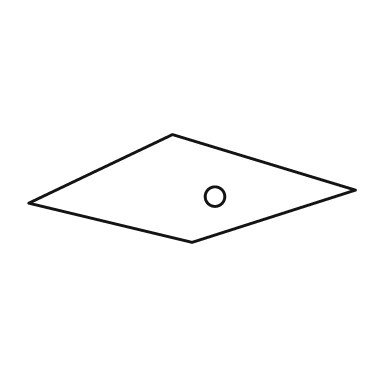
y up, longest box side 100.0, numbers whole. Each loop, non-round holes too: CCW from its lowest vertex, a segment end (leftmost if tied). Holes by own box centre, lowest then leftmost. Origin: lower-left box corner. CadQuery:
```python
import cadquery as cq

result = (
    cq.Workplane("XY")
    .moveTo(50.0, 0.0)
    .lineTo(100.0, 16.0)
    .lineTo(44.0, 33.0)
    .lineTo(0.0, 12.0)
    .close()
    .moveTo(57.0, 14.0)
    .circle(3.0)
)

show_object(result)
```